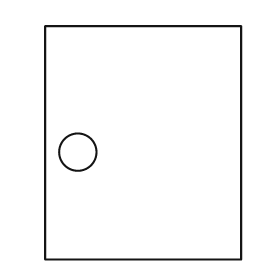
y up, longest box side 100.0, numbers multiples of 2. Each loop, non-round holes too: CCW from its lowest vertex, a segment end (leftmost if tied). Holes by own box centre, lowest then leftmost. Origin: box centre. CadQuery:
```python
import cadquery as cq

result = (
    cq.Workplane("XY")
    .moveTo(-42.0, -50.0)
    .lineTo(42.0, -50.0)
    .lineTo(42.0, 50.0)
    .lineTo(-42.0, 50.0)
    .close()
    .moveTo(-28.0, -4.0)
    .circle(8.0)
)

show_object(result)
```